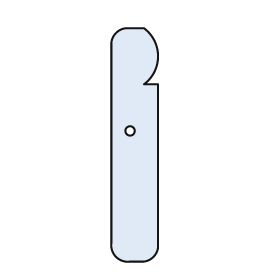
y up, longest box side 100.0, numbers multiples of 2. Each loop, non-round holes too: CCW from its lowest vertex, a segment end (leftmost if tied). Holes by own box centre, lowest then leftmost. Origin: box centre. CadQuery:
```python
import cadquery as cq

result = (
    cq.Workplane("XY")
    .moveTo(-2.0, -50.0)
    .lineTo(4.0, -50.0)
    .threePointArc((8.0, -48.0), (10.0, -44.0))
    .lineTo(10.0, 26.0)
    .lineTo(4.0, 26.0)
    .threePointArc((10.0, 38.0), (4.0, 50.0))
    .lineTo(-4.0, 50.0)
    .threePointArc((-8.0, 48.0), (-10.0, 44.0))
    .lineTo(-10.0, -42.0)
    .threePointArc((-8.0, -48.0), (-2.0, -50.0))
    .close()
    .moveTo(-2.0, 6.0)
    .circle(2.0)
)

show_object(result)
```